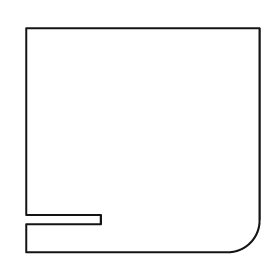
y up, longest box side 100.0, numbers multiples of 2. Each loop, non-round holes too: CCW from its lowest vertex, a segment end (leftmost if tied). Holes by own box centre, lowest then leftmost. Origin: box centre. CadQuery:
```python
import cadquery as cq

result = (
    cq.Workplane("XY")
    .moveTo(-50.0, -48.0)
    .lineTo(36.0, -48.0)
    .threePointArc((46.0, -44.0), (50.0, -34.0))
    .lineTo(50.0, 48.0)
    .lineTo(-50.0, 48.0)
    .lineTo(-50.0, -32.0)
    .lineTo(-18.0, -32.0)
    .lineTo(-18.0, -36.0)
    .lineTo(-50.0, -36.0)
    .close()
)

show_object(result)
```